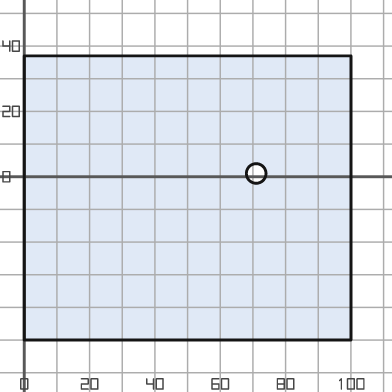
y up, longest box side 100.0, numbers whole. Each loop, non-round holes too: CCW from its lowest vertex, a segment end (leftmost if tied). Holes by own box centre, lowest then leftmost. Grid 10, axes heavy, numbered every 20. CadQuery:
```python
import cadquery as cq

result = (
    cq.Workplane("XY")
    .moveTo(0.0, -50.0)
    .lineTo(100.0, -50.0)
    .lineTo(100.0, 37.0)
    .lineTo(0.0, 37.0)
    .close()
    .moveTo(71.0, 1.0)
    .circle(3.0)
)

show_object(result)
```